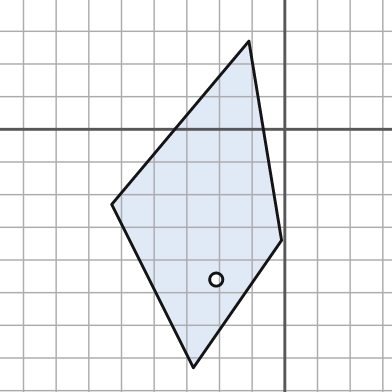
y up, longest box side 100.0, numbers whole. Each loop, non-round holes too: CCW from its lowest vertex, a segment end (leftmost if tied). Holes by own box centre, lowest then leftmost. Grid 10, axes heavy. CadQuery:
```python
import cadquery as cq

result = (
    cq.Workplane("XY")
    .moveTo(-28.0, -73.0)
    .lineTo(-1.0, -34.0)
    .lineTo(-11.0, 27.0)
    .lineTo(-53.0, -23.0)
    .close()
    .moveTo(-21.0, -46.0)
    .circle(2.0)
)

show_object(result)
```